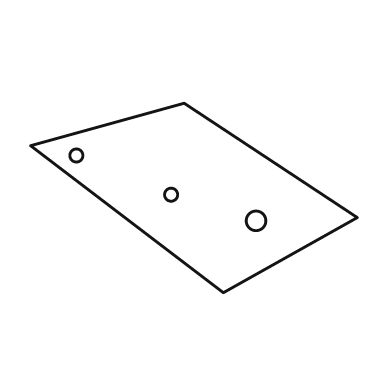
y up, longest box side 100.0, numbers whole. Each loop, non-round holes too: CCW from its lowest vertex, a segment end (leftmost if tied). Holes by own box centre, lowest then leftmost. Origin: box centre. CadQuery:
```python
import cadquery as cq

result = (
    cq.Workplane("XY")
    .moveTo(9.0, -29.0)
    .lineTo(50.0, -6.0)
    .lineTo(-3.0, 29.0)
    .lineTo(-50.0, 16.0)
    .close()
    .moveTo(19.0, -7.0)
    .circle(3.0)
    .moveTo(-7.0, 1.0)
    .circle(2.0)
    .moveTo(-36.0, 13.0)
    .circle(2.0)
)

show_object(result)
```